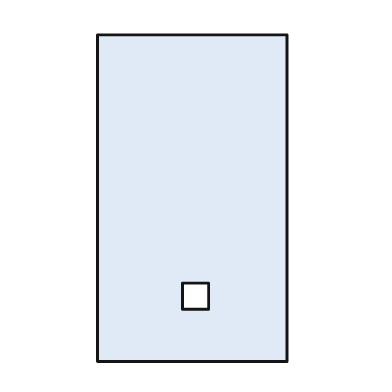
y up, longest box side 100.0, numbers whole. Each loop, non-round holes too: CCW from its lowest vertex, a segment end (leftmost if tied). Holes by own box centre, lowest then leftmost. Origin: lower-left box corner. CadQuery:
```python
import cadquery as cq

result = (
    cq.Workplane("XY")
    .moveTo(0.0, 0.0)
    .lineTo(58.0, 0.0)
    .lineTo(58.0, 100.0)
    .lineTo(0.0, 100.0)
    .close()
    .moveTo(26.0, 16.0)
    .lineTo(34.0, 16.0)
    .lineTo(34.0, 24.0)
    .lineTo(26.0, 24.0)
    .close()
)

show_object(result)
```